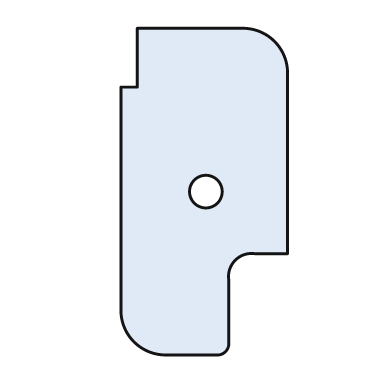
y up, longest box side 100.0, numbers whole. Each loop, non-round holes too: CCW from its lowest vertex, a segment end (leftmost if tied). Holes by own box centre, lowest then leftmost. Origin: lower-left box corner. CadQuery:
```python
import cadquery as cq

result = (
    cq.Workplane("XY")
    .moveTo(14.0, 0.0)
    .lineTo(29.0, 0.0)
    .threePointArc((32.0, 1.0), (33.0, 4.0))
    .lineTo(33.0, 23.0)
    .threePointArc((35.0, 29.0), (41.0, 31.0))
    .lineTo(51.0, 31.0)
    .lineTo(51.0, 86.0)
    .threePointArc((47.0, 96.0), (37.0, 100.0))
    .lineTo(5.0, 100.0)
    .lineTo(5.0, 82.0)
    .lineTo(0.0, 82.0)
    .lineTo(0.0, 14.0)
    .threePointArc((4.0, 4.0), (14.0, 0.0))
    .close()
    .moveTo(26.0, 50.0)
    .circle(5.0)
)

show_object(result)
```